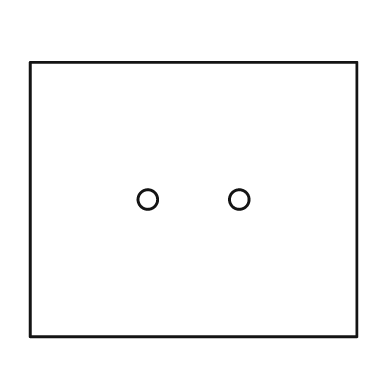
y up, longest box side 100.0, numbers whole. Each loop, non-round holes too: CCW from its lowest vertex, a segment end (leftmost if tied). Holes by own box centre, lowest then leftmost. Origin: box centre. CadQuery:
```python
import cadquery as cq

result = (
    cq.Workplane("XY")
    .moveTo(-50.0, -42.0)
    .lineTo(50.0, -42.0)
    .lineTo(50.0, 42.0)
    .lineTo(-50.0, 42.0)
    .close()
    .moveTo(-14.0, 0.0)
    .circle(3.0)
    .moveTo(14.0, 0.0)
    .circle(3.0)
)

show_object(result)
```